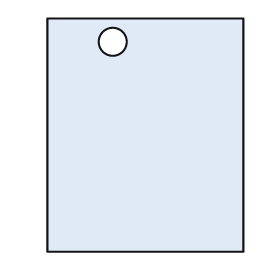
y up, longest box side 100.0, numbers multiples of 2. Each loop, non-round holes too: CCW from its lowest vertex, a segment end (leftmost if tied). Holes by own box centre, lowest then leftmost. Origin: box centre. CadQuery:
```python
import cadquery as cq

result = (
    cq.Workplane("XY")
    .moveTo(-42.0, -50.0)
    .lineTo(42.0, -50.0)
    .lineTo(42.0, 50.0)
    .lineTo(-42.0, 50.0)
    .close()
    .moveTo(-14.0, 40.0)
    .circle(6.0)
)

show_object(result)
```